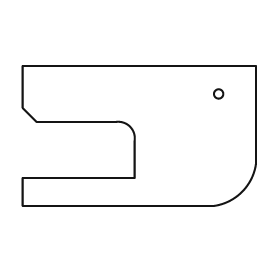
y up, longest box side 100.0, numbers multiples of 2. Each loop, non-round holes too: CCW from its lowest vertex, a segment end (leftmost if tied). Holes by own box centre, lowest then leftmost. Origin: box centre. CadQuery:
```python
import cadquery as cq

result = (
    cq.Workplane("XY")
    .moveTo(-50.0, -30.0)
    .lineTo(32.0, -30.0)
    .threePointArc((44.0, -24.0), (50.0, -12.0))
    .lineTo(50.0, 30.0)
    .lineTo(-50.0, 30.0)
    .lineTo(-50.0, 12.0)
    .lineTo(-44.0, 6.0)
    .lineTo(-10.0, 6.0)
    .threePointArc((-4.0, 4.0), (-2.0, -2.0))
    .lineTo(-2.0, -18.0)
    .lineTo(-50.0, -18.0)
    .close()
    .moveTo(34.0, 18.0)
    .circle(2.0)
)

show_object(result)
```